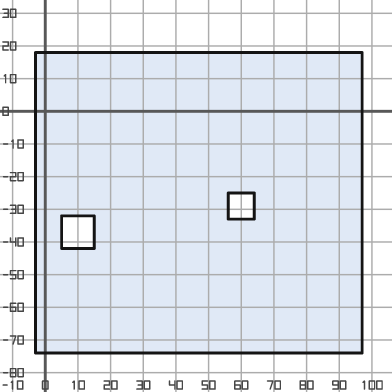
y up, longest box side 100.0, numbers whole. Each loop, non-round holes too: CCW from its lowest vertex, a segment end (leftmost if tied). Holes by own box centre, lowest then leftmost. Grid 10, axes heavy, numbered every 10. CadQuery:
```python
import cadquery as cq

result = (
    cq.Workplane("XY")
    .moveTo(-3.0, -74.0)
    .lineTo(97.0, -74.0)
    .lineTo(97.0, 18.0)
    .lineTo(-3.0, 18.0)
    .close()
    .moveTo(5.0, -42.0)
    .lineTo(15.0, -42.0)
    .lineTo(15.0, -32.0)
    .lineTo(5.0, -32.0)
    .close()
    .moveTo(56.0, -33.0)
    .lineTo(64.0, -33.0)
    .lineTo(64.0, -25.0)
    .lineTo(56.0, -25.0)
    .close()
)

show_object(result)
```